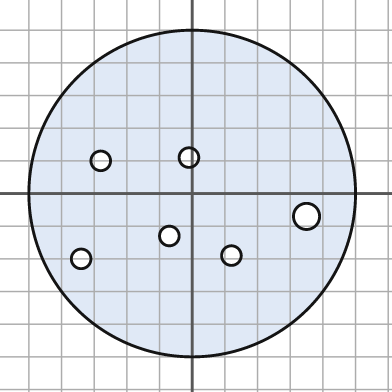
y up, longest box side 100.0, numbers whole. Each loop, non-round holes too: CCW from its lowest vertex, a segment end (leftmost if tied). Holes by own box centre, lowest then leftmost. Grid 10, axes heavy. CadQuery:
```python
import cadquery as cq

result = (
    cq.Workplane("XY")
    .moveTo(0.0, 0.0)
    .circle(50.0)
    .moveTo(-34.0, -20.0)
    .circle(3.0)
    .moveTo(12.0, -19.0)
    .circle(3.0)
    .moveTo(-7.0, -13.0)
    .circle(3.0)
    .moveTo(35.0, -7.0)
    .circle(4.0)
    .moveTo(-28.0, 10.0)
    .circle(3.0)
    .moveTo(-1.0, 11.0)
    .circle(3.0)
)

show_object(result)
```